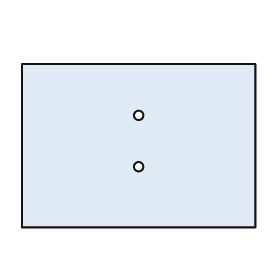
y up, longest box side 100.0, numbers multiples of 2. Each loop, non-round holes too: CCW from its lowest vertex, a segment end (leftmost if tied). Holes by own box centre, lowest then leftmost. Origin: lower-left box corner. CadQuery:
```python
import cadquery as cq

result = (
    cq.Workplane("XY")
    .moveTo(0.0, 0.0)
    .lineTo(100.0, 0.0)
    .lineTo(100.0, 70.0)
    .lineTo(0.0, 70.0)
    .close()
    .moveTo(50.0, 26.0)
    .circle(2.0)
    .moveTo(50.0, 48.0)
    .circle(2.0)
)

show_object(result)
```